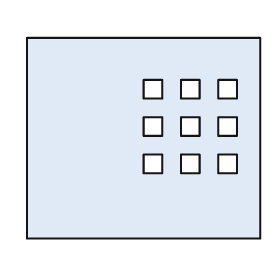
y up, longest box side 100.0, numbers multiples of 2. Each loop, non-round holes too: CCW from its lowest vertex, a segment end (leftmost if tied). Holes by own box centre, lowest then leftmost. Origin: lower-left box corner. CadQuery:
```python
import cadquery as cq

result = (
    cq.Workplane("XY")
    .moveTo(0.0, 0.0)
    .lineTo(100.0, 0.0)
    .lineTo(100.0, 86.0)
    .lineTo(0.0, 86.0)
    .close()
    .moveTo(50.0, 28.0)
    .lineTo(58.0, 28.0)
    .lineTo(58.0, 36.0)
    .lineTo(50.0, 36.0)
    .close()
    .moveTo(66.0, 28.0)
    .lineTo(74.0, 28.0)
    .lineTo(74.0, 36.0)
    .lineTo(66.0, 36.0)
    .close()
    .moveTo(82.0, 28.0)
    .lineTo(90.0, 28.0)
    .lineTo(90.0, 36.0)
    .lineTo(82.0, 36.0)
    .close()
    .moveTo(50.0, 44.0)
    .lineTo(58.0, 44.0)
    .lineTo(58.0, 52.0)
    .lineTo(50.0, 52.0)
    .close()
    .moveTo(66.0, 44.0)
    .lineTo(74.0, 44.0)
    .lineTo(74.0, 52.0)
    .lineTo(66.0, 52.0)
    .close()
    .moveTo(82.0, 44.0)
    .lineTo(90.0, 44.0)
    .lineTo(90.0, 52.0)
    .lineTo(82.0, 52.0)
    .close()
    .moveTo(50.0, 60.0)
    .lineTo(58.0, 60.0)
    .lineTo(58.0, 68.0)
    .lineTo(50.0, 68.0)
    .close()
    .moveTo(66.0, 60.0)
    .lineTo(74.0, 60.0)
    .lineTo(74.0, 68.0)
    .lineTo(66.0, 68.0)
    .close()
    .moveTo(82.0, 60.0)
    .lineTo(90.0, 60.0)
    .lineTo(90.0, 68.0)
    .lineTo(82.0, 68.0)
    .close()
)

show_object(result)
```